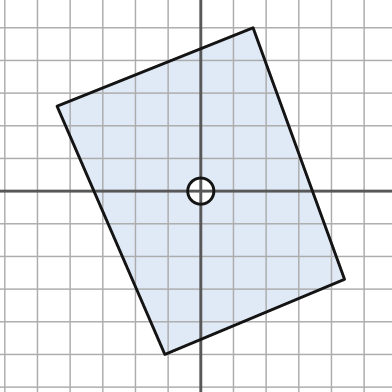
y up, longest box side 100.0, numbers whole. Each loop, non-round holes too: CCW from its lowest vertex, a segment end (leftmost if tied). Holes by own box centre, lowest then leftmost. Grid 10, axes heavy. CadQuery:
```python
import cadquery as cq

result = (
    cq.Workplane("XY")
    .moveTo(-11.0, -50.0)
    .lineTo(44.0, -27.0)
    .lineTo(16.0, 50.0)
    .lineTo(-44.0, 26.0)
    .close()
    .moveTo(0.0, 0.0)
    .circle(4.0)
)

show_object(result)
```